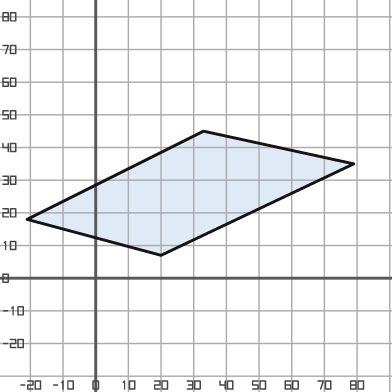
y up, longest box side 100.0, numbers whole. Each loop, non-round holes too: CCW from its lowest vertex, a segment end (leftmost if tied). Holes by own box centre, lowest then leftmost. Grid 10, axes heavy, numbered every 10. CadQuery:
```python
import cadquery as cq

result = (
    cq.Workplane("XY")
    .moveTo(20.0, 7.0)
    .lineTo(79.0, 35.0)
    .lineTo(33.0, 45.0)
    .lineTo(-21.0, 18.0)
    .close()
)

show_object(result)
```